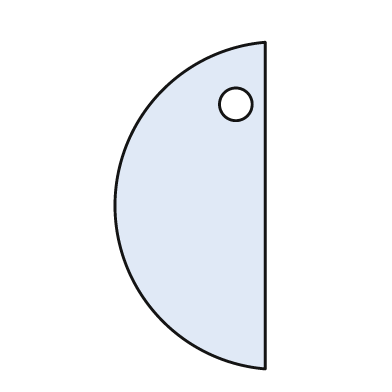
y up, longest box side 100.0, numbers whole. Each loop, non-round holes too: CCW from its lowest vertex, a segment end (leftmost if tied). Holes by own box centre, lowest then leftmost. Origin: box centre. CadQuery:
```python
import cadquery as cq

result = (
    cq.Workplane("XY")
    .moveTo(23.0, -50.0)
    .lineTo(23.0, 50.0)
    .threePointArc((-23.0, 0.0), (23.0, -50.0))
    .close()
    .moveTo(14.0, 31.0)
    .circle(5.0)
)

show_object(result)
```